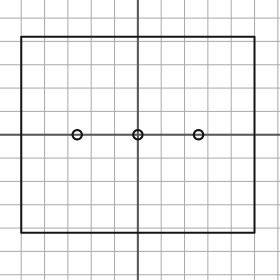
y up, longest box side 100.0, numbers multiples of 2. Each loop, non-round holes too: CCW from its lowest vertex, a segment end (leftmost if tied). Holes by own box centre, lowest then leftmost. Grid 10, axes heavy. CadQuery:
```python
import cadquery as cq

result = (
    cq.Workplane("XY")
    .moveTo(-50.0, -42.0)
    .lineTo(50.0, -42.0)
    .lineTo(50.0, 42.0)
    .lineTo(-50.0, 42.0)
    .close()
    .moveTo(-26.0, 0.0)
    .circle(2.0)
    .moveTo(0.0, 0.0)
    .circle(2.0)
    .moveTo(26.0, 0.0)
    .circle(2.0)
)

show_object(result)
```